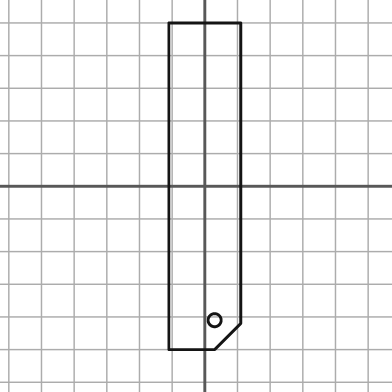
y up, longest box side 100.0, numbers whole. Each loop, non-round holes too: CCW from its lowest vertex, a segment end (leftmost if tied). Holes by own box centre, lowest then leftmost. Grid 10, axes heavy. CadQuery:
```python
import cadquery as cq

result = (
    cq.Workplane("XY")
    .moveTo(-11.0, -50.0)
    .lineTo(3.0, -50.0)
    .lineTo(11.0, -42.0)
    .lineTo(11.0, 50.0)
    .lineTo(-11.0, 50.0)
    .close()
    .moveTo(3.0, -41.0)
    .circle(2.0)
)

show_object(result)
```